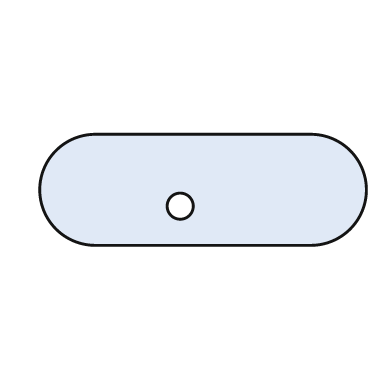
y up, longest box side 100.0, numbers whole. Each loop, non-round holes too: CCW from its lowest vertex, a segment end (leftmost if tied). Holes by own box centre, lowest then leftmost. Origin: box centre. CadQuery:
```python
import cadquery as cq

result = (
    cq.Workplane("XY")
    .moveTo(-33.0, -17.0)
    .lineTo(33.0, -17.0)
    .threePointArc((50.0, 0.0), (33.0, 17.0))
    .lineTo(-33.0, 17.0)
    .threePointArc((-50.0, 0.0), (-33.0, -17.0))
    .close()
    .moveTo(-7.0, -5.0)
    .circle(4.0)
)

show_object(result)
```